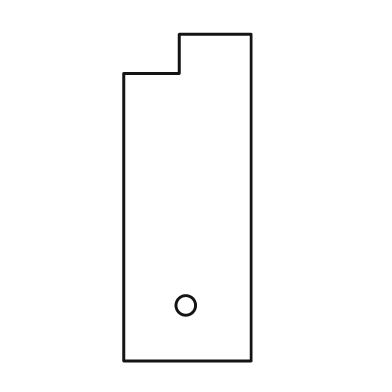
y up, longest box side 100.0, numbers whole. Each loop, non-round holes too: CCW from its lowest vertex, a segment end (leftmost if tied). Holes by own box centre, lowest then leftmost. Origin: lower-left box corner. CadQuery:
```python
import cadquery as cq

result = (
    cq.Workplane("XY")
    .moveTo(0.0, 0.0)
    .lineTo(39.0, 0.0)
    .lineTo(39.0, 100.0)
    .lineTo(17.0, 100.0)
    .lineTo(17.0, 88.0)
    .lineTo(0.0, 88.0)
    .close()
    .moveTo(19.0, 17.0)
    .circle(3.0)
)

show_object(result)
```